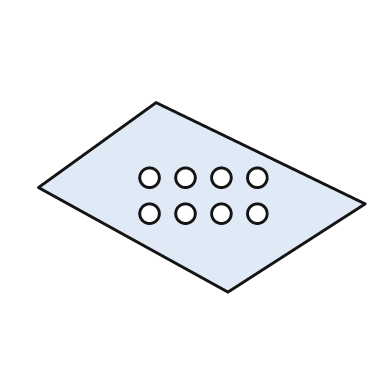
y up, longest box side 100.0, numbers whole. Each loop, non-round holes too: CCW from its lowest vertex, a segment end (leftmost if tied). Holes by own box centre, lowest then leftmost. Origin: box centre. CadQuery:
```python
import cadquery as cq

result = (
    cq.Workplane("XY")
    .moveTo(8.0, -29.0)
    .lineTo(50.0, -2.0)
    .lineTo(-14.0, 29.0)
    .lineTo(-50.0, 3.0)
    .close()
    .moveTo(-16.0, -5.0)
    .circle(3.0)
    .moveTo(-5.0, -5.0)
    .circle(3.0)
    .moveTo(6.0, -5.0)
    .circle(3.0)
    .moveTo(17.0, -5.0)
    .circle(3.0)
    .moveTo(-16.0, 6.0)
    .circle(3.0)
    .moveTo(-5.0, 6.0)
    .circle(3.0)
    .moveTo(6.0, 6.0)
    .circle(3.0)
    .moveTo(17.0, 6.0)
    .circle(3.0)
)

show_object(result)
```